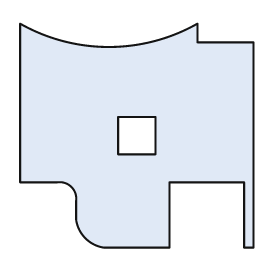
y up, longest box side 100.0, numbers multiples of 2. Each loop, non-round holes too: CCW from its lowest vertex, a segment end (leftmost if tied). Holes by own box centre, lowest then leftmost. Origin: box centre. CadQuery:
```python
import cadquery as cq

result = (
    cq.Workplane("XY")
    .moveTo(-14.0, -48.0)
    .lineTo(14.0, -48.0)
    .lineTo(14.0, -20.0)
    .lineTo(46.0, -20.0)
    .lineTo(46.0, -48.0)
    .lineTo(50.0, -48.0)
    .lineTo(50.0, 40.0)
    .lineTo(26.0, 40.0)
    .lineTo(26.0, 48.0)
    .threePointArc((-12.0, 38.0), (-50.0, 48.0))
    .lineTo(-50.0, -20.0)
    .lineTo(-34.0, -20.0)
    .threePointArc((-28.0, -22.0), (-26.0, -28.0))
    .lineTo(-26.0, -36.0)
    .threePointArc((-22.0, -44.0), (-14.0, -48.0))
    .close()
    .moveTo(-8.0, -8.0)
    .lineTo(8.0, -8.0)
    .lineTo(8.0, 8.0)
    .lineTo(-8.0, 8.0)
    .close()
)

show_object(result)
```